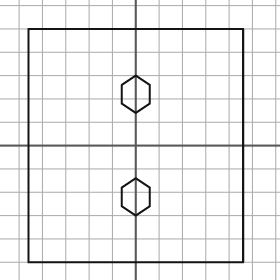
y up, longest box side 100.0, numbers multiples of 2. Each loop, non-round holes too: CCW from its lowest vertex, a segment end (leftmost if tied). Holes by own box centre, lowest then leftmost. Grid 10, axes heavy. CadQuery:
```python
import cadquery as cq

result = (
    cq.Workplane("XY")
    .moveTo(-46.0, -50.0)
    .lineTo(46.0, -50.0)
    .lineTo(46.0, 50.0)
    .lineTo(-46.0, 50.0)
    .close()
    .moveTo(0.0, -30.0)
    .lineTo(6.0, -26.0)
    .lineTo(6.0, -18.0)
    .lineTo(0.0, -14.0)
    .lineTo(-6.0, -18.0)
    .lineTo(-6.0, -26.0)
    .close()
    .moveTo(0.0, 14.0)
    .lineTo(6.0, 18.0)
    .lineTo(6.0, 26.0)
    .lineTo(0.0, 30.0)
    .lineTo(-6.0, 26.0)
    .lineTo(-6.0, 18.0)
    .close()
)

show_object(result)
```